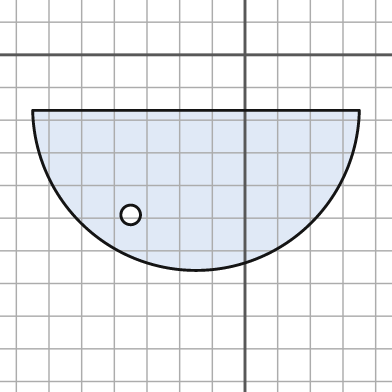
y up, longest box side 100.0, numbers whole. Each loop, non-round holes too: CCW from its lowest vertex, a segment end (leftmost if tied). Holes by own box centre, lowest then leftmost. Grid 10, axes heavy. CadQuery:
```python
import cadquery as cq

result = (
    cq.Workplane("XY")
    .moveTo(-65.0, -17.0)
    .threePointArc((-15.0, -66.0), (35.0, -17.0))
    .close()
    .moveTo(-35.0, -49.0)
    .circle(3.0)
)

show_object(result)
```